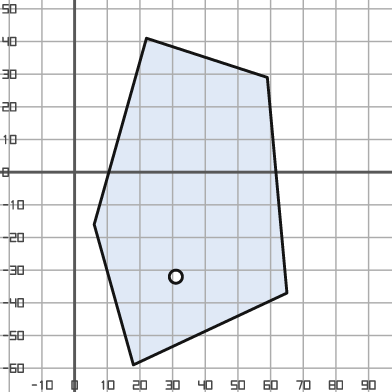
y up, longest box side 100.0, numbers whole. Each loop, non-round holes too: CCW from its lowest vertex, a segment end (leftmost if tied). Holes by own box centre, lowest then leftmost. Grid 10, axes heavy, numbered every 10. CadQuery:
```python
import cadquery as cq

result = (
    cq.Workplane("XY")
    .moveTo(18.0, -59.0)
    .lineTo(65.0, -37.0)
    .lineTo(59.0, 29.0)
    .lineTo(22.0, 41.0)
    .lineTo(6.0, -16.0)
    .close()
    .moveTo(31.0, -32.0)
    .circle(2.0)
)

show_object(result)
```